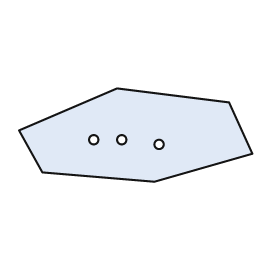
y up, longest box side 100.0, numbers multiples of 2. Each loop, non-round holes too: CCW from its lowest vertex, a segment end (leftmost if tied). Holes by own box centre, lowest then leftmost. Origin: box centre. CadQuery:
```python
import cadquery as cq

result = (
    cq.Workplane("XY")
    .moveTo(8.0, -20.0)
    .lineTo(50.0, -8.0)
    .lineTo(40.0, 14.0)
    .lineTo(-8.0, 20.0)
    .lineTo(-50.0, 2.0)
    .lineTo(-40.0, -16.0)
    .close()
    .moveTo(10.0, -4.0)
    .circle(2.0)
    .moveTo(-18.0, -2.0)
    .circle(2.0)
    .moveTo(-6.0, -2.0)
    .circle(2.0)
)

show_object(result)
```